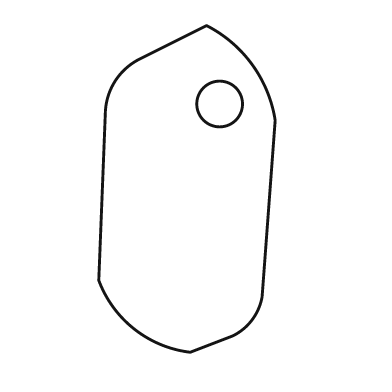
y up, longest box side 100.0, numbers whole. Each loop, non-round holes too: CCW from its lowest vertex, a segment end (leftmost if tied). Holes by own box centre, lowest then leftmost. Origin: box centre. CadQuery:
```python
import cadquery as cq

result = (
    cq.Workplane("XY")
    .moveTo(1.0, -50.0)
    .lineTo(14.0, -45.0)
    .threePointArc((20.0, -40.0), (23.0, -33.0))
    .lineTo(27.0, 21.0)
    .threePointArc((20.0, 38.0), (6.0, 50.0))
    .lineTo(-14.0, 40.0)
    .threePointArc((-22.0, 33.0), (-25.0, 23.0))
    .lineTo(-27.0, -28.0)
    .threePointArc((-16.0, -43.0), (1.0, -50.0))
    .close()
    .moveTo(10.0, 26.0)
    .circle(7.0)
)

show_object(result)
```